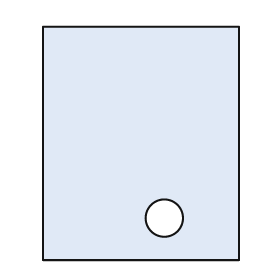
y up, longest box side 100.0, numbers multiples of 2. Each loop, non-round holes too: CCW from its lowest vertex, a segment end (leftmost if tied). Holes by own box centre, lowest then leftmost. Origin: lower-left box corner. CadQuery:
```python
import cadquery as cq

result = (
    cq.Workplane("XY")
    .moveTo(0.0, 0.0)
    .lineTo(84.0, 0.0)
    .lineTo(84.0, 100.0)
    .lineTo(0.0, 100.0)
    .close()
    .moveTo(52.0, 18.0)
    .circle(8.0)
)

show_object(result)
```